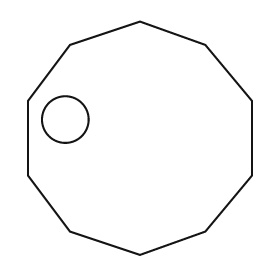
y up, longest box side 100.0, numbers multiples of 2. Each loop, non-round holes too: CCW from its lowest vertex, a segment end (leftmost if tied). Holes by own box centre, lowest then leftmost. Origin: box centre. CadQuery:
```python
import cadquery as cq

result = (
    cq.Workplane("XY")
    .moveTo(0.0, -50.0)
    .lineTo(28.0, -40.0)
    .lineTo(48.0, -16.0)
    .lineTo(48.0, 16.0)
    .lineTo(28.0, 40.0)
    .lineTo(0.0, 50.0)
    .lineTo(-30.0, 40.0)
    .lineTo(-48.0, 16.0)
    .lineTo(-48.0, -16.0)
    .lineTo(-30.0, -40.0)
    .close()
    .moveTo(-32.0, 8.0)
    .circle(10.0)
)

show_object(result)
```